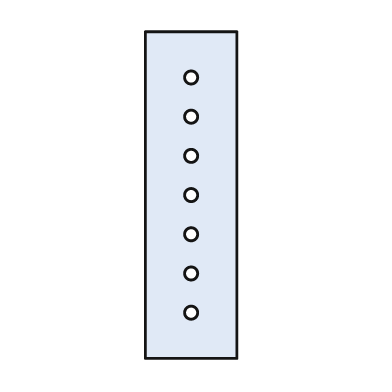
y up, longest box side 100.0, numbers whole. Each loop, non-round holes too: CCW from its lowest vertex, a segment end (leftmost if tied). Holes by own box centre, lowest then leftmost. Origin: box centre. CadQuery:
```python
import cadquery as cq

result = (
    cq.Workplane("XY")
    .moveTo(-14.0, -50.0)
    .lineTo(14.0, -50.0)
    .lineTo(14.0, 50.0)
    .lineTo(-14.0, 50.0)
    .close()
    .moveTo(0.0, -36.0)
    .circle(2.0)
    .moveTo(0.0, -24.0)
    .circle(2.0)
    .moveTo(0.0, -12.0)
    .circle(2.0)
    .moveTo(0.0, 0.0)
    .circle(2.0)
    .moveTo(0.0, 12.0)
    .circle(2.0)
    .moveTo(0.0, 24.0)
    .circle(2.0)
    .moveTo(0.0, 36.0)
    .circle(2.0)
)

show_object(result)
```